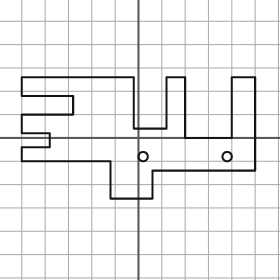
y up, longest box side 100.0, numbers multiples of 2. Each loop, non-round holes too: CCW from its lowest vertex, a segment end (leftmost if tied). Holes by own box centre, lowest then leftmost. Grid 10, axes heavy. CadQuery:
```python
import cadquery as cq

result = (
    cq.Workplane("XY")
    .moveTo(-12.0, -26.0)
    .lineTo(6.0, -26.0)
    .lineTo(6.0, -14.0)
    .lineTo(50.0, -14.0)
    .lineTo(50.0, 26.0)
    .lineTo(40.0, 26.0)
    .lineTo(40.0, 0.0)
    .lineTo(20.0, 0.0)
    .lineTo(20.0, 26.0)
    .lineTo(12.0, 26.0)
    .lineTo(12.0, 4.0)
    .lineTo(-2.0, 4.0)
    .lineTo(-2.0, 26.0)
    .lineTo(-50.0, 26.0)
    .lineTo(-50.0, 18.0)
    .lineTo(-28.0, 18.0)
    .lineTo(-28.0, 10.0)
    .lineTo(-50.0, 10.0)
    .lineTo(-50.0, 2.0)
    .lineTo(-38.0, 2.0)
    .lineTo(-38.0, -4.0)
    .lineTo(-50.0, -4.0)
    .lineTo(-50.0, -10.0)
    .lineTo(-12.0, -10.0)
    .close()
    .moveTo(2.0, -8.0)
    .circle(2.0)
    .moveTo(38.0, -8.0)
    .circle(2.0)
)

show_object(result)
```